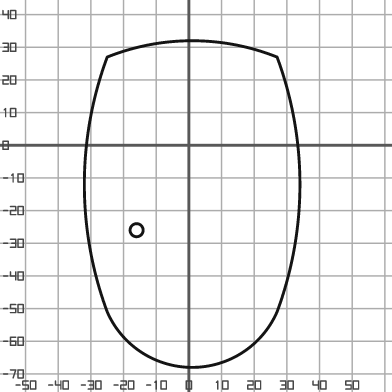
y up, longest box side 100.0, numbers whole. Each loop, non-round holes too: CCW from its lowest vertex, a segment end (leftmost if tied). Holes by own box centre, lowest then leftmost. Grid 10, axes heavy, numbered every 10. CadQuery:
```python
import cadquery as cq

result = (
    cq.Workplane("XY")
    .moveTo(-25.0, -51.0)
    .threePointArc((1.0, -68.0), (27.0, -51.0))
    .threePointArc((34.0, -12.0), (27.0, 27.0))
    .threePointArc((1.0, 32.0), (-25.0, 27.0))
    .threePointArc((-32.0, -12.0), (-25.0, -51.0))
    .close()
    .moveTo(-16.0, -26.0)
    .circle(2.0)
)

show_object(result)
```